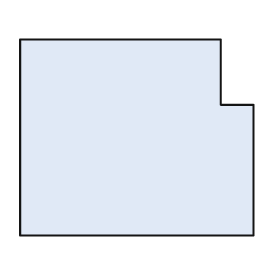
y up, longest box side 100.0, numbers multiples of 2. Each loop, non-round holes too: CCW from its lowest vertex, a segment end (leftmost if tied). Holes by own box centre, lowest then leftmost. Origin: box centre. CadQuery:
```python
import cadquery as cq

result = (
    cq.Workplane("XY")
    .moveTo(-50.0, -42.0)
    .lineTo(50.0, -42.0)
    .lineTo(50.0, 14.0)
    .lineTo(36.0, 14.0)
    .lineTo(36.0, 42.0)
    .lineTo(-50.0, 42.0)
    .close()
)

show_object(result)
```